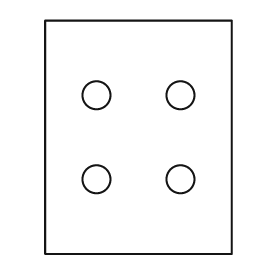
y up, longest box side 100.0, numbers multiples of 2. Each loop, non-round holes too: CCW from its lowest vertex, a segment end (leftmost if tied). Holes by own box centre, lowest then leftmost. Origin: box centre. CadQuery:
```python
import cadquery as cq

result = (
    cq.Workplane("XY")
    .moveTo(-40.0, -50.0)
    .lineTo(40.0, -50.0)
    .lineTo(40.0, 50.0)
    .lineTo(-40.0, 50.0)
    .close()
    .moveTo(-18.0, -18.0)
    .circle(6.0)
    .moveTo(18.0, -18.0)
    .circle(6.0)
    .moveTo(-18.0, 18.0)
    .circle(6.0)
    .moveTo(18.0, 18.0)
    .circle(6.0)
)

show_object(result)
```